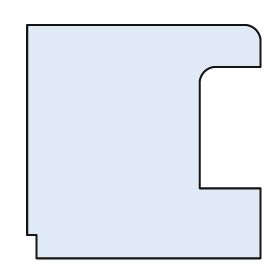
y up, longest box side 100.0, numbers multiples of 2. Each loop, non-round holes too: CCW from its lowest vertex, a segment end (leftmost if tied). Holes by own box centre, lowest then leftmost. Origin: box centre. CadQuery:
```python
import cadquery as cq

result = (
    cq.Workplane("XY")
    .moveTo(-46.0, -50.0)
    .lineTo(50.0, -50.0)
    .lineTo(50.0, -20.0)
    .lineTo(24.0, -20.0)
    .lineTo(24.0, 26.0)
    .threePointArc((26.0, 30.0), (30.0, 32.0))
    .lineTo(50.0, 32.0)
    .lineTo(50.0, 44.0)
    .threePointArc((48.0, 48.0), (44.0, 50.0))
    .lineTo(-50.0, 50.0)
    .lineTo(-50.0, -40.0)
    .lineTo(-46.0, -40.0)
    .close()
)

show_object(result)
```